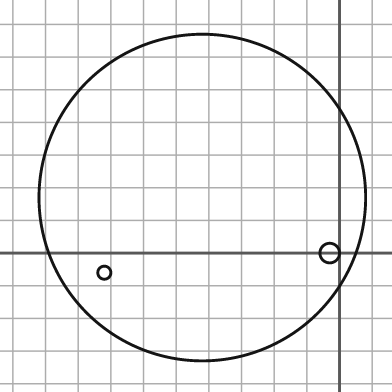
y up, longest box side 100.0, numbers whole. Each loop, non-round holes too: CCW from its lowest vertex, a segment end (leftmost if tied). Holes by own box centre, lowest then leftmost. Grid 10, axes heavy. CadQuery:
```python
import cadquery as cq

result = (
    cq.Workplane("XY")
    .moveTo(-42.0, 17.0)
    .circle(50.0)
    .moveTo(-72.0, -6.0)
    .circle(2.0)
    .moveTo(-3.0, 0.0)
    .circle(3.0)
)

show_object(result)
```